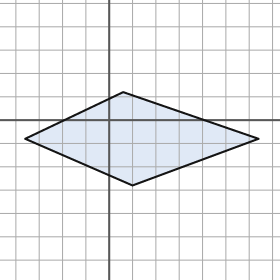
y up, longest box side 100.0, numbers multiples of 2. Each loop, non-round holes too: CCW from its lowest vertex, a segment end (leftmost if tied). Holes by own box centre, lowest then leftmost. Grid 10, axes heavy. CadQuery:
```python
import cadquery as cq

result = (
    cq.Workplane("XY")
    .moveTo(10.0, -28.0)
    .lineTo(64.0, -8.0)
    .lineTo(6.0, 12.0)
    .lineTo(-36.0, -8.0)
    .close()
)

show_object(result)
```